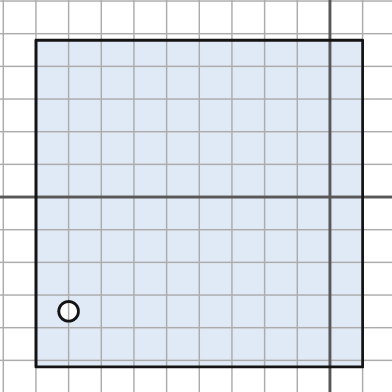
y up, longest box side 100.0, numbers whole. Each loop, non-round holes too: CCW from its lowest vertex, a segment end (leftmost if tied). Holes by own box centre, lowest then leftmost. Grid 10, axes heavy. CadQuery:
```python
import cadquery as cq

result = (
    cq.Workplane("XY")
    .moveTo(-90.0, -52.0)
    .lineTo(10.0, -52.0)
    .lineTo(10.0, 48.0)
    .lineTo(-90.0, 48.0)
    .close()
    .moveTo(-80.0, -35.0)
    .circle(3.0)
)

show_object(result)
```